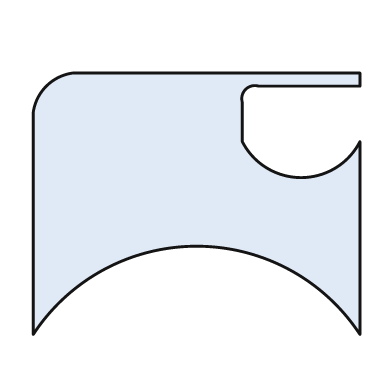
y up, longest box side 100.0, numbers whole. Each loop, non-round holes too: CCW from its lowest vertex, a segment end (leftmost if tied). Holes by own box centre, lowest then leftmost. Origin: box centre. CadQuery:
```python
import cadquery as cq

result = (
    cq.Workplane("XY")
    .moveTo(-50.0, -40.0)
    .threePointArc((0.0, -13.0), (50.0, -40.0))
    .lineTo(50.0, 19.0)
    .threePointArc((32.0, 8.0), (14.0, 19.0))
    .lineTo(14.0, 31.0)
    .threePointArc((15.0, 35.0), (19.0, 36.0))
    .lineTo(50.0, 36.0)
    .lineTo(50.0, 40.0)
    .lineTo(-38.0, 40.0)
    .threePointArc((-46.0, 36.0), (-50.0, 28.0))
    .close()
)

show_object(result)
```